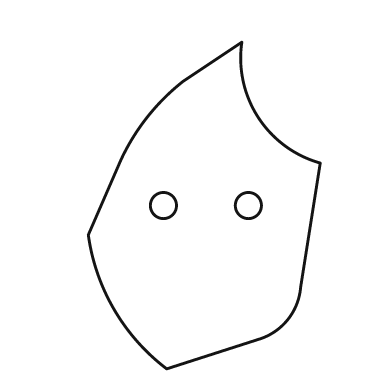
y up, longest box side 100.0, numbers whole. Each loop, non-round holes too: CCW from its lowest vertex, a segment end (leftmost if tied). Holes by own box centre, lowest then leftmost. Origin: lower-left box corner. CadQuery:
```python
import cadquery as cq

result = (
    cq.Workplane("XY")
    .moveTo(24.0, 0.0)
    .lineTo(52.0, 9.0)
    .threePointArc((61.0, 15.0), (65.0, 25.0))
    .lineTo(71.0, 63.0)
    .threePointArc((52.0, 77.0), (47.0, 100.0))
    .lineTo(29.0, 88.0)
    .threePointArc((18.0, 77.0), (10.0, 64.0))
    .lineTo(0.0, 41.0)
    .threePointArc((8.0, 18.0), (24.0, 0.0))
    .close()
    .moveTo(23.0, 50.0)
    .circle(4.0)
    .moveTo(49.0, 50.0)
    .circle(4.0)
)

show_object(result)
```